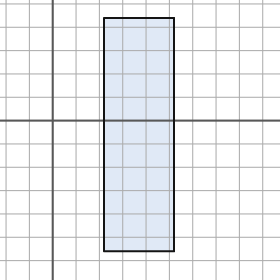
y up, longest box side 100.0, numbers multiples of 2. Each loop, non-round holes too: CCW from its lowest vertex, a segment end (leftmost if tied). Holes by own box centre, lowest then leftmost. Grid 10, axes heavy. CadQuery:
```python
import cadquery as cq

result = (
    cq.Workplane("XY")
    .moveTo(22.0, -56.0)
    .lineTo(52.0, -56.0)
    .lineTo(52.0, 44.0)
    .lineTo(22.0, 44.0)
    .close()
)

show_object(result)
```